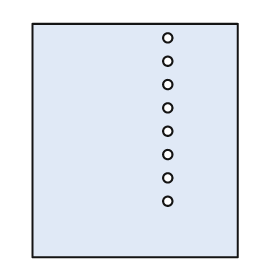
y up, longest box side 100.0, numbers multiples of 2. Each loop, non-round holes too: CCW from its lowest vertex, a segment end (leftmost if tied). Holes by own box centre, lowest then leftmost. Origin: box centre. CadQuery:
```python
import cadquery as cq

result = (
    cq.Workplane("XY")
    .moveTo(-44.0, -50.0)
    .lineTo(44.0, -50.0)
    .lineTo(44.0, 50.0)
    .lineTo(-44.0, 50.0)
    .close()
    .moveTo(14.0, -26.0)
    .circle(2.0)
    .moveTo(14.0, -16.0)
    .circle(2.0)
    .moveTo(14.0, -6.0)
    .circle(2.0)
    .moveTo(14.0, 4.0)
    .circle(2.0)
    .moveTo(14.0, 14.0)
    .circle(2.0)
    .moveTo(14.0, 24.0)
    .circle(2.0)
    .moveTo(14.0, 34.0)
    .circle(2.0)
    .moveTo(14.0, 44.0)
    .circle(2.0)
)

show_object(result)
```